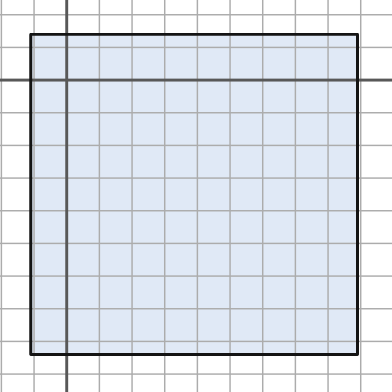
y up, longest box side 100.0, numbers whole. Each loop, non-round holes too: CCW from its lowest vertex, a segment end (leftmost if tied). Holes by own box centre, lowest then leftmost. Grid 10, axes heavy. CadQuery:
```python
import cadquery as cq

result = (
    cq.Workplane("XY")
    .moveTo(-11.0, -84.0)
    .lineTo(89.0, -84.0)
    .lineTo(89.0, 14.0)
    .lineTo(-11.0, 14.0)
    .close()
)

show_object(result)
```